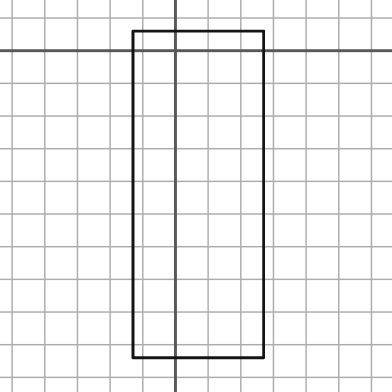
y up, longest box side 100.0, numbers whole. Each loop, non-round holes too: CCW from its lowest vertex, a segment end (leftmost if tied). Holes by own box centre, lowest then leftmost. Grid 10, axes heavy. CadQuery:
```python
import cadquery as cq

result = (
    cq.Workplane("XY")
    .moveTo(-13.0, -94.0)
    .lineTo(27.0, -94.0)
    .lineTo(27.0, 6.0)
    .lineTo(-13.0, 6.0)
    .close()
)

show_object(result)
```